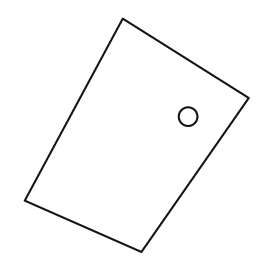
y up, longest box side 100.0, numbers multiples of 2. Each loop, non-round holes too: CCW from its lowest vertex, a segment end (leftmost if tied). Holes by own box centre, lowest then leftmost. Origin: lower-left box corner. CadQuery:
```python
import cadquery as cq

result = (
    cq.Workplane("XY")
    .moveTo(50.0, 0.0)
    .lineTo(96.0, 66.0)
    .lineTo(42.0, 100.0)
    .lineTo(0.0, 22.0)
    .close()
    .moveTo(70.0, 58.0)
    .circle(4.0)
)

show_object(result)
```